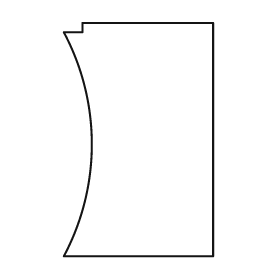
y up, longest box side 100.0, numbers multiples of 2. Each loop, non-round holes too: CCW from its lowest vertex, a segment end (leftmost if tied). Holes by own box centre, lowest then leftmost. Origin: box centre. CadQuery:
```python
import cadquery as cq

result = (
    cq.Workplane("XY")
    .moveTo(-32.0, -50.0)
    .lineTo(32.0, -50.0)
    .lineTo(32.0, 50.0)
    .lineTo(-24.0, 50.0)
    .lineTo(-24.0, 46.0)
    .lineTo(-32.0, 46.0)
    .threePointArc((-20.0, -2.0), (-32.0, -50.0))
    .close()
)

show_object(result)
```